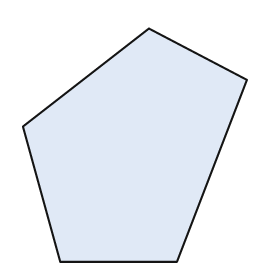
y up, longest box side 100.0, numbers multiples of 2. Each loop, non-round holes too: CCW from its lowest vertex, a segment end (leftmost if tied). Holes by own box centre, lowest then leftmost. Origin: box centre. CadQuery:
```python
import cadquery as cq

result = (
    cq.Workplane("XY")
    .moveTo(-32.0, -50.0)
    .lineTo(18.0, -50.0)
    .lineTo(48.0, 28.0)
    .lineTo(6.0, 50.0)
    .lineTo(-48.0, 8.0)
    .close()
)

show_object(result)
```